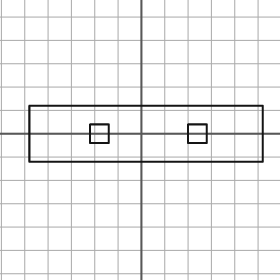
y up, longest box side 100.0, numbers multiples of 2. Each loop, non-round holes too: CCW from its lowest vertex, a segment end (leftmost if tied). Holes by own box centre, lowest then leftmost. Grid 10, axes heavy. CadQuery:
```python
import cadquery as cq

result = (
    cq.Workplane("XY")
    .moveTo(-48.0, -12.0)
    .lineTo(52.0, -12.0)
    .lineTo(52.0, 12.0)
    .lineTo(-48.0, 12.0)
    .close()
    .moveTo(-22.0, -4.0)
    .lineTo(-14.0, -4.0)
    .lineTo(-14.0, 4.0)
    .lineTo(-22.0, 4.0)
    .close()
    .moveTo(20.0, -4.0)
    .lineTo(28.0, -4.0)
    .lineTo(28.0, 4.0)
    .lineTo(20.0, 4.0)
    .close()
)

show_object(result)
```